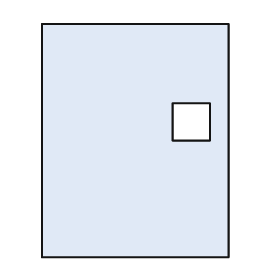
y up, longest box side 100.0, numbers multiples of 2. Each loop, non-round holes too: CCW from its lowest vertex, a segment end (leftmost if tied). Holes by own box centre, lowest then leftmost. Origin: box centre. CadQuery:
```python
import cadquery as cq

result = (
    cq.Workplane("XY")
    .moveTo(-40.0, -50.0)
    .lineTo(40.0, -50.0)
    .lineTo(40.0, 50.0)
    .lineTo(-40.0, 50.0)
    .close()
    .moveTo(16.0, 0.0)
    .lineTo(32.0, 0.0)
    .lineTo(32.0, 16.0)
    .lineTo(16.0, 16.0)
    .close()
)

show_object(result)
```